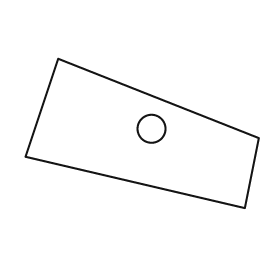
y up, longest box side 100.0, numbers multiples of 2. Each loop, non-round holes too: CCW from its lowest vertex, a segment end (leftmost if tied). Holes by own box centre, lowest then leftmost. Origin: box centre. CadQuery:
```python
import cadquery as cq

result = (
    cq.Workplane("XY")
    .moveTo(44.0, -32.0)
    .lineTo(50.0, -2.0)
    .lineTo(-36.0, 32.0)
    .lineTo(-50.0, -10.0)
    .close()
    .moveTo(4.0, 2.0)
    .circle(6.0)
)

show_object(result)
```